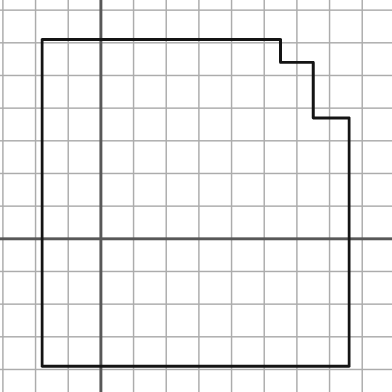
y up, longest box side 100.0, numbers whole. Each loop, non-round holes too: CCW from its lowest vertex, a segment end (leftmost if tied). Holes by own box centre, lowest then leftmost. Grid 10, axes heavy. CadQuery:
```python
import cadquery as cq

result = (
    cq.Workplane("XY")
    .moveTo(-18.0, -39.0)
    .lineTo(76.0, -39.0)
    .lineTo(76.0, 37.0)
    .lineTo(65.0, 37.0)
    .lineTo(65.0, 54.0)
    .lineTo(55.0, 54.0)
    .lineTo(55.0, 61.0)
    .lineTo(-18.0, 61.0)
    .close()
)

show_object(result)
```